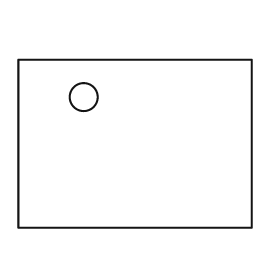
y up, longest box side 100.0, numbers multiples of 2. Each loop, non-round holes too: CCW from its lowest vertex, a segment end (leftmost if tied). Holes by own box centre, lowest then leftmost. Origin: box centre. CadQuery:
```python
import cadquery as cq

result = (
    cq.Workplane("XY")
    .moveTo(-50.0, -36.0)
    .lineTo(50.0, -36.0)
    .lineTo(50.0, 36.0)
    .lineTo(-50.0, 36.0)
    .close()
    .moveTo(-22.0, 20.0)
    .circle(6.0)
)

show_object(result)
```